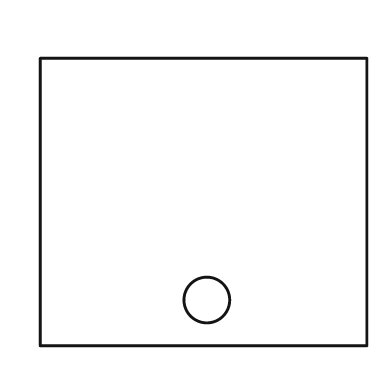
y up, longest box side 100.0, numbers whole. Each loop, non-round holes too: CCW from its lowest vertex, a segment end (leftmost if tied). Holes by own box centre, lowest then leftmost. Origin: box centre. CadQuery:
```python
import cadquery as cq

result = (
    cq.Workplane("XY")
    .moveTo(-50.0, -44.0)
    .lineTo(50.0, -44.0)
    .lineTo(50.0, 44.0)
    .lineTo(-50.0, 44.0)
    .close()
    .moveTo(1.0, -30.0)
    .circle(7.0)
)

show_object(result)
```